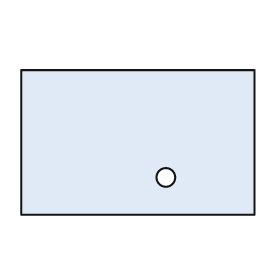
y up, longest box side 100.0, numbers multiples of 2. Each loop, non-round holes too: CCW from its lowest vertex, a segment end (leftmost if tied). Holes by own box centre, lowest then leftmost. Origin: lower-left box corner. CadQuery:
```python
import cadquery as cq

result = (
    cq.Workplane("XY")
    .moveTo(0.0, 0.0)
    .lineTo(100.0, 0.0)
    .lineTo(100.0, 62.0)
    .lineTo(0.0, 62.0)
    .close()
    .moveTo(62.0, 16.0)
    .circle(4.0)
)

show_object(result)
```